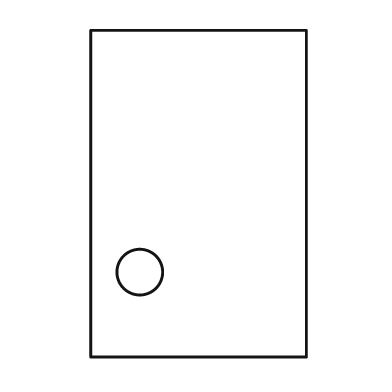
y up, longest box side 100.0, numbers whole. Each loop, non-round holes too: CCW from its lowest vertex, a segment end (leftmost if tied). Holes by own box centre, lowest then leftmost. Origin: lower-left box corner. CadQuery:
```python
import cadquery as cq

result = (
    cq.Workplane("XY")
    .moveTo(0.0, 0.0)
    .lineTo(66.0, 0.0)
    .lineTo(66.0, 100.0)
    .lineTo(0.0, 100.0)
    .close()
    .moveTo(15.0, 26.0)
    .circle(7.0)
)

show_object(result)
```